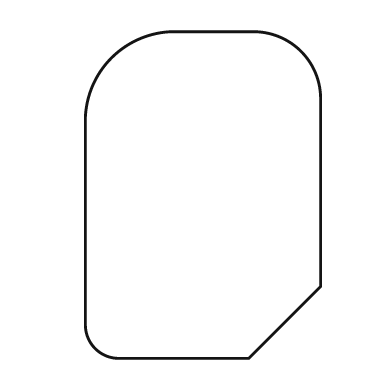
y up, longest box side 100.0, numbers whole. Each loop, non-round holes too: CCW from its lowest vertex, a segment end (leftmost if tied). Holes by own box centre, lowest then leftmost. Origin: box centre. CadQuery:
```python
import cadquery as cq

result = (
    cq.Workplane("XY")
    .moveTo(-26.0, -50.0)
    .lineTo(14.0, -50.0)
    .lineTo(36.0, -28.0)
    .lineTo(36.0, 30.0)
    .threePointArc((30.0, 44.0), (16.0, 50.0))
    .lineTo(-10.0, 50.0)
    .threePointArc((-28.0, 42.0), (-36.0, 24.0))
    .lineTo(-36.0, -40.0)
    .threePointArc((-33.0, -47.0), (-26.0, -50.0))
    .close()
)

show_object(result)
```